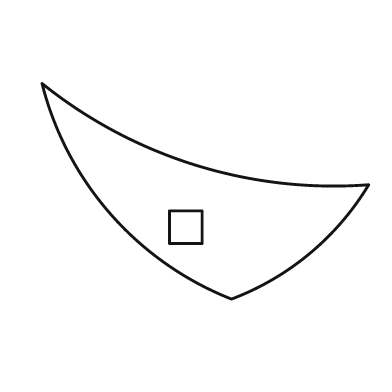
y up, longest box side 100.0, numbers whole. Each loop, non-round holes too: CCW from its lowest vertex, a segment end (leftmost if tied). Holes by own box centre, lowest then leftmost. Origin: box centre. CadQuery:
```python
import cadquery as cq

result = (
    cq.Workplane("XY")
    .moveTo(8.0, -33.0)
    .threePointArc((32.0, -19.0), (50.0, 2.0))
    .threePointArc((-3.0, 8.0), (-50.0, 33.0))
    .threePointArc((-29.0, -7.0), (8.0, -33.0))
    .close()
    .moveTo(-11.0, -16.0)
    .lineTo(-1.0, -16.0)
    .lineTo(-1.0, -6.0)
    .lineTo(-11.0, -6.0)
    .close()
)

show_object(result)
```